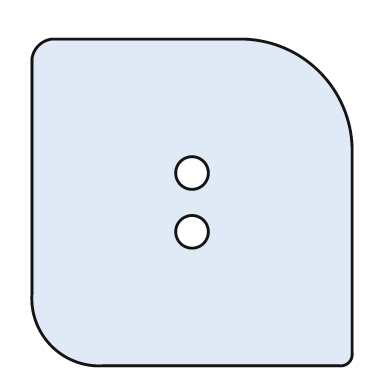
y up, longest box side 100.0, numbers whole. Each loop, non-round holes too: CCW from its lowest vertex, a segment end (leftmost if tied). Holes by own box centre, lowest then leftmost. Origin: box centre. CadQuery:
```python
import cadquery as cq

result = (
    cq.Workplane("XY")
    .moveTo(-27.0, -50.0)
    .lineTo(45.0, -50.0)
    .threePointArc((48.0, -49.0), (49.0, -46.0))
    .lineTo(49.0, 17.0)
    .threePointArc((39.0, 40.0), (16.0, 50.0))
    .lineTo(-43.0, 50.0)
    .threePointArc((-47.0, 48.0), (-49.0, 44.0))
    .lineTo(-49.0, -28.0)
    .threePointArc((-43.0, -44.0), (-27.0, -50.0))
    .close()
    .moveTo(0.0, -9.0)
    .circle(5.0)
    .moveTo(0.0, 9.0)
    .circle(5.0)
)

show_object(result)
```